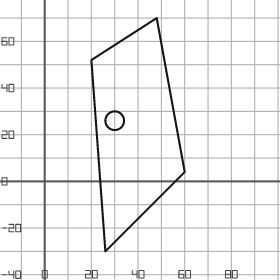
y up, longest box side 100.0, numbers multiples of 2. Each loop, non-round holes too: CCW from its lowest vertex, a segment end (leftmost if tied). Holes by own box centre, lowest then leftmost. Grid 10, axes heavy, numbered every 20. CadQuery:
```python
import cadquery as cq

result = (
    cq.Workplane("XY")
    .moveTo(26.0, -30.0)
    .lineTo(60.0, 4.0)
    .lineTo(48.0, 70.0)
    .lineTo(20.0, 52.0)
    .close()
    .moveTo(30.0, 26.0)
    .circle(4.0)
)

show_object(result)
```